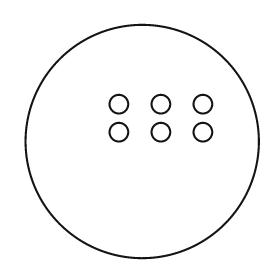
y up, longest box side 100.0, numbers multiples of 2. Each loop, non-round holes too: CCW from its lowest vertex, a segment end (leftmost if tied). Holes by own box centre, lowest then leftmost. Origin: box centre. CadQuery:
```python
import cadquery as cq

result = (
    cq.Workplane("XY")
    .moveTo(0.0, 0.0)
    .circle(50.0)
    .moveTo(-10.0, 4.0)
    .circle(4.0)
    .moveTo(8.0, 4.0)
    .circle(4.0)
    .moveTo(26.0, 4.0)
    .circle(4.0)
    .moveTo(-10.0, 16.0)
    .circle(4.0)
    .moveTo(8.0, 16.0)
    .circle(4.0)
    .moveTo(26.0, 16.0)
    .circle(4.0)
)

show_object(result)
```